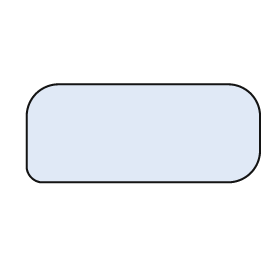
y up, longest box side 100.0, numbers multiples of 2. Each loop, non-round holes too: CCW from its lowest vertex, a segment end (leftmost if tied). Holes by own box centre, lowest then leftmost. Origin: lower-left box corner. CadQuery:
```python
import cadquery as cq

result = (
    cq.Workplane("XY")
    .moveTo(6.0, 0.0)
    .lineTo(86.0, 0.0)
    .threePointArc((96.0, 4.0), (100.0, 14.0))
    .lineTo(100.0, 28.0)
    .threePointArc((96.0, 38.0), (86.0, 42.0))
    .lineTo(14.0, 42.0)
    .threePointArc((4.0, 38.0), (0.0, 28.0))
    .lineTo(0.0, 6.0)
    .threePointArc((2.0, 2.0), (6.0, 0.0))
    .close()
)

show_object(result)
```